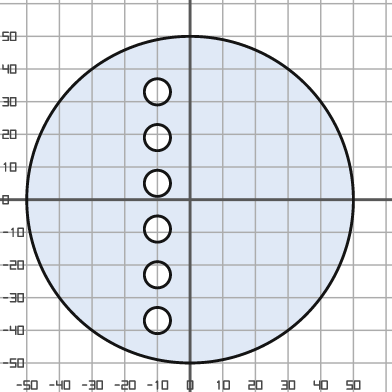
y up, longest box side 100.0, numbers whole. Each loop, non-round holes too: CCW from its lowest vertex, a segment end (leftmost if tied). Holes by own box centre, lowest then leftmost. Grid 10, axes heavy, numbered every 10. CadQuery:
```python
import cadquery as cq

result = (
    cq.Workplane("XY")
    .moveTo(0.0, 0.0)
    .circle(50.0)
    .moveTo(-10.0, -37.0)
    .circle(4.0)
    .moveTo(-10.0, -23.0)
    .circle(4.0)
    .moveTo(-10.0, -9.0)
    .circle(4.0)
    .moveTo(-10.0, 5.0)
    .circle(4.0)
    .moveTo(-10.0, 19.0)
    .circle(4.0)
    .moveTo(-10.0, 33.0)
    .circle(4.0)
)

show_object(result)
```